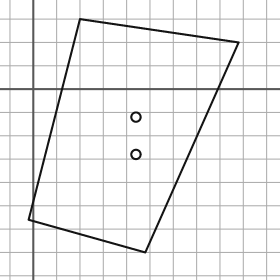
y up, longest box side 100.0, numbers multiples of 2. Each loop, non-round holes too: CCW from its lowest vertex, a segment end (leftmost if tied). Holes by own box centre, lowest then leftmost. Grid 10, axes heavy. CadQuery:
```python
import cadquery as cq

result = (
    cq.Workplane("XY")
    .moveTo(48.0, -70.0)
    .lineTo(88.0, 20.0)
    .lineTo(20.0, 30.0)
    .lineTo(-2.0, -56.0)
    .close()
    .moveTo(44.0, -28.0)
    .circle(2.0)
    .moveTo(44.0, -12.0)
    .circle(2.0)
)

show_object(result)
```